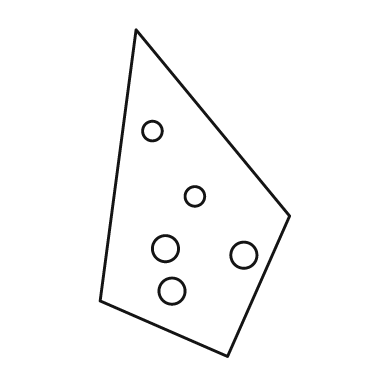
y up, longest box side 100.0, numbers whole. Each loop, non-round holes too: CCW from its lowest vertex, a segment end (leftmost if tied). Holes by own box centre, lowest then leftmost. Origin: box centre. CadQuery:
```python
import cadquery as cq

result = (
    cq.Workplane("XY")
    .moveTo(10.0, -50.0)
    .lineTo(29.0, -7.0)
    .lineTo(-18.0, 50.0)
    .lineTo(-29.0, -33.0)
    .close()
    .moveTo(-7.0, -30.0)
    .circle(4.0)
    .moveTo(15.0, -19.0)
    .circle(4.0)
    .moveTo(-9.0, -17.0)
    .circle(4.0)
    .moveTo(0.0, -1.0)
    .circle(3.0)
    .moveTo(-13.0, 19.0)
    .circle(3.0)
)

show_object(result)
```